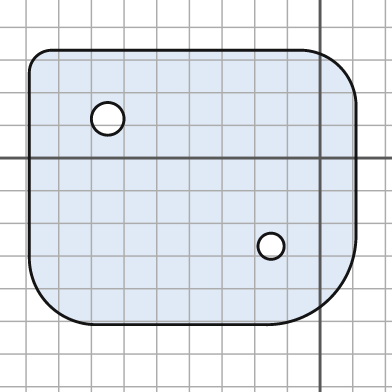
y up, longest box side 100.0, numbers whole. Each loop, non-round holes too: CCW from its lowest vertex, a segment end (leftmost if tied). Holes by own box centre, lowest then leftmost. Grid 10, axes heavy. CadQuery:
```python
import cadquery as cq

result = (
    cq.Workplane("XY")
    .moveTo(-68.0, -51.0)
    .lineTo(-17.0, -51.0)
    .threePointArc((3.0, -43.0), (11.0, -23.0))
    .lineTo(11.0, 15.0)
    .threePointArc((6.0, 28.0), (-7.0, 33.0))
    .lineTo(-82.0, 33.0)
    .threePointArc((-87.0, 31.0), (-89.0, 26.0))
    .lineTo(-89.0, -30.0)
    .threePointArc((-83.0, -45.0), (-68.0, -51.0))
    .close()
    .moveTo(-15.0, -27.0)
    .circle(4.0)
    .moveTo(-65.0, 12.0)
    .circle(5.0)
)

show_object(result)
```